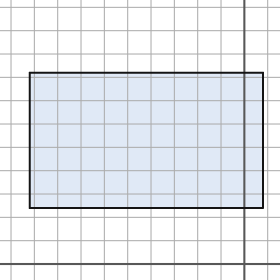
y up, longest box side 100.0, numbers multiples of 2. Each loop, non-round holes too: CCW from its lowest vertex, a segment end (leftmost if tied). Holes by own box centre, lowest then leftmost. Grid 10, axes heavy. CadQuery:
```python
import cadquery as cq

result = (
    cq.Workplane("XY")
    .moveTo(-92.0, 24.0)
    .lineTo(8.0, 24.0)
    .lineTo(8.0, 82.0)
    .lineTo(-92.0, 82.0)
    .close()
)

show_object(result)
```